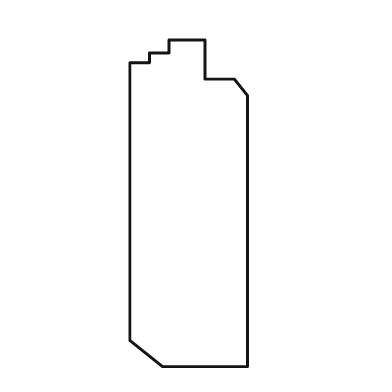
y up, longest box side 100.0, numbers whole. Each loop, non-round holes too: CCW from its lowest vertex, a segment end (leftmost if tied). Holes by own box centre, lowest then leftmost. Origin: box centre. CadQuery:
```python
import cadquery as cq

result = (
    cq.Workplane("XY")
    .moveTo(-8.0, -50.0)
    .lineTo(18.0, -50.0)
    .lineTo(18.0, 33.0)
    .lineTo(14.0, 38.0)
    .lineTo(5.0, 38.0)
    .lineTo(5.0, 50.0)
    .lineTo(-6.0, 50.0)
    .lineTo(-6.0, 46.0)
    .lineTo(-12.0, 46.0)
    .lineTo(-12.0, 43.0)
    .lineTo(-18.0, 43.0)
    .lineTo(-18.0, -42.0)
    .close()
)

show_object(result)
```